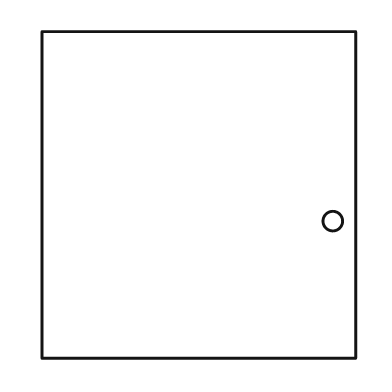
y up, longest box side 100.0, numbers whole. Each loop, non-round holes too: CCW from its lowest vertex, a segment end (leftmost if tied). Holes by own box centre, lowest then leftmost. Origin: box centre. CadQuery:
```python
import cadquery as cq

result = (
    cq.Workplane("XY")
    .moveTo(-48.0, -50.0)
    .lineTo(48.0, -50.0)
    .lineTo(48.0, 50.0)
    .lineTo(-48.0, 50.0)
    .close()
    .moveTo(41.0, -8.0)
    .circle(3.0)
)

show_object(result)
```